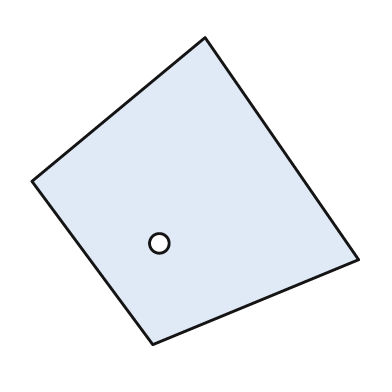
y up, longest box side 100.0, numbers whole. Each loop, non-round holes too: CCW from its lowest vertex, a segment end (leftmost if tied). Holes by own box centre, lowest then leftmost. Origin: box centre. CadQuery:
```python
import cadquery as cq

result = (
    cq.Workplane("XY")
    .moveTo(-13.0, -47.0)
    .lineTo(50.0, -21.0)
    .lineTo(3.0, 47.0)
    .lineTo(-50.0, 3.0)
    .close()
    .moveTo(-11.0, -16.0)
    .circle(3.0)
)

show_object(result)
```